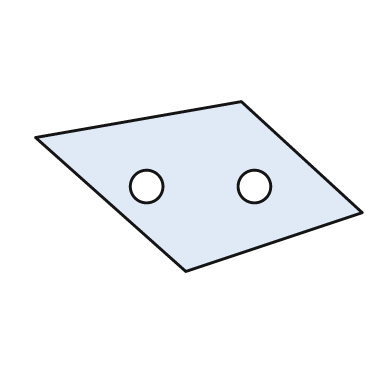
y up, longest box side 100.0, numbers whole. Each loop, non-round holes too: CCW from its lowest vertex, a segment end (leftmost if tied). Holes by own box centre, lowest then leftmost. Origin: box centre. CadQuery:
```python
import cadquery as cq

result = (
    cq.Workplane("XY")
    .moveTo(-4.0, -26.0)
    .lineTo(50.0, -8.0)
    .lineTo(13.0, 26.0)
    .lineTo(-50.0, 15.0)
    .close()
    .moveTo(-16.0, 0.0)
    .circle(5.0)
    .moveTo(17.0, 0.0)
    .circle(5.0)
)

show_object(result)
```